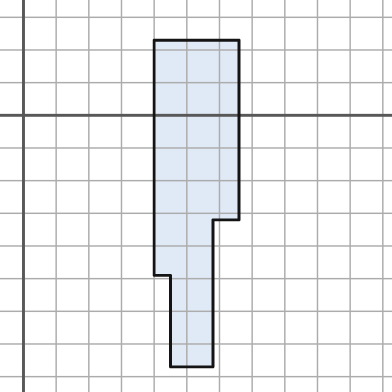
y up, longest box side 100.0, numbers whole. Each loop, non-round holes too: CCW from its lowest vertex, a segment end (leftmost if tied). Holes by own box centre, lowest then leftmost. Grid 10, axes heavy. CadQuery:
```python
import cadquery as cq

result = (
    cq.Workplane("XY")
    .moveTo(45.0, -77.0)
    .lineTo(58.0, -77.0)
    .lineTo(58.0, -32.0)
    .lineTo(66.0, -32.0)
    .lineTo(66.0, 23.0)
    .lineTo(40.0, 23.0)
    .lineTo(40.0, -49.0)
    .lineTo(45.0, -49.0)
    .close()
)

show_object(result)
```